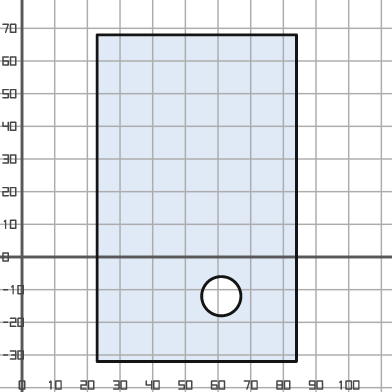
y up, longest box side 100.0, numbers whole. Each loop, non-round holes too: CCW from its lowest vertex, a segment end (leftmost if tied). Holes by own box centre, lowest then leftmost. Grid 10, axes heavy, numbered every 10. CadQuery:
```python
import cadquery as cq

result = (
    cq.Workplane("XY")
    .moveTo(23.0, -32.0)
    .lineTo(84.0, -32.0)
    .lineTo(84.0, 68.0)
    .lineTo(23.0, 68.0)
    .close()
    .moveTo(61.0, -12.0)
    .circle(6.0)
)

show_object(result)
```